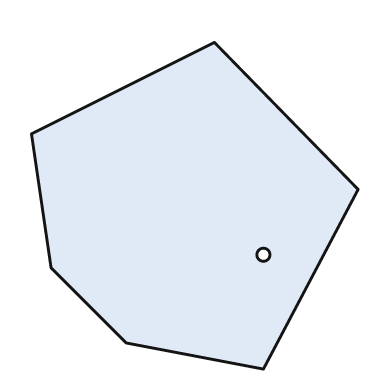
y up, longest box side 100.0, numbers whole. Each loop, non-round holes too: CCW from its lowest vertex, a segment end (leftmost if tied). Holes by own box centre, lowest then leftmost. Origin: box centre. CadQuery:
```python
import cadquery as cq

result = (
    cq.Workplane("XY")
    .moveTo(21.0, -50.0)
    .lineTo(50.0, 5.0)
    .lineTo(6.0, 50.0)
    .lineTo(-50.0, 22.0)
    .lineTo(-44.0, -19.0)
    .lineTo(-21.0, -42.0)
    .close()
    .moveTo(21.0, -15.0)
    .circle(2.0)
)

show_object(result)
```